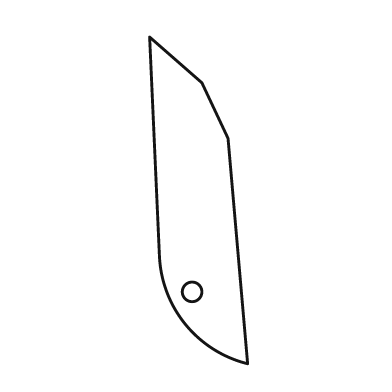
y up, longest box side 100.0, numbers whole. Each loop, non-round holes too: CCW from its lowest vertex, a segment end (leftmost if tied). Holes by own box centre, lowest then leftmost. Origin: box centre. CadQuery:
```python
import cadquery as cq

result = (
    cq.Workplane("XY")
    .moveTo(15.0, -50.0)
    .lineTo(9.0, 19.0)
    .lineTo(1.0, 36.0)
    .lineTo(-15.0, 50.0)
    .lineTo(-12.0, -17.0)
    .threePointArc((-4.0, -38.0), (15.0, -50.0))
    .close()
    .moveTo(-2.0, -28.0)
    .circle(3.0)
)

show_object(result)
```